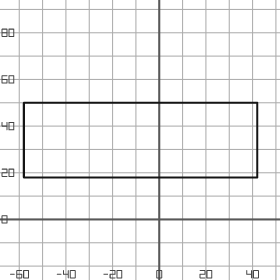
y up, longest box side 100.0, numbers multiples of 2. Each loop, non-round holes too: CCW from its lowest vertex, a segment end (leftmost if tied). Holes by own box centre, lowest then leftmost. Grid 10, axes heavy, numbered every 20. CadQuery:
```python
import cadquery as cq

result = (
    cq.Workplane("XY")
    .moveTo(-58.0, 18.0)
    .lineTo(42.0, 18.0)
    .lineTo(42.0, 50.0)
    .lineTo(-58.0, 50.0)
    .close()
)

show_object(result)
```